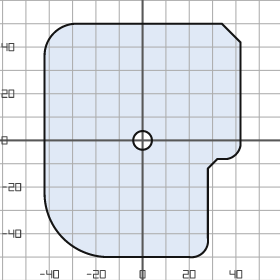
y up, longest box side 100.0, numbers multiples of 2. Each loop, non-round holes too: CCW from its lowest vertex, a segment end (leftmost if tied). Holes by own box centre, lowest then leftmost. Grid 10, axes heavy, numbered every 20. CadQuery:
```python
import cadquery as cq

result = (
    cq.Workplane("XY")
    .moveTo(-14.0, -50.0)
    .lineTo(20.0, -50.0)
    .threePointArc((26.0, -48.0), (28.0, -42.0))
    .lineTo(28.0, -12.0)
    .lineTo(32.0, -8.0)
    .lineTo(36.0, -8.0)
    .threePointArc((40.0, -6.0), (42.0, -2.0))
    .lineTo(42.0, 42.0)
    .lineTo(34.0, 50.0)
    .lineTo(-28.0, 50.0)
    .threePointArc((-38.0, 46.0), (-42.0, 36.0))
    .lineTo(-42.0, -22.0)
    .threePointArc((-34.0, -42.0), (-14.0, -50.0))
    .close()
    .moveTo(0.0, 0.0)
    .circle(4.0)
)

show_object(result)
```